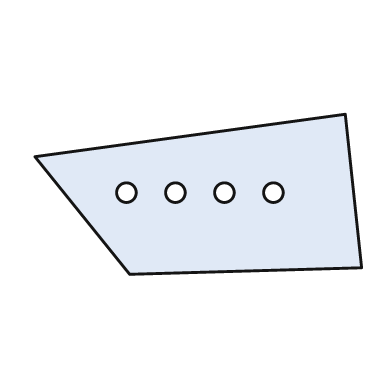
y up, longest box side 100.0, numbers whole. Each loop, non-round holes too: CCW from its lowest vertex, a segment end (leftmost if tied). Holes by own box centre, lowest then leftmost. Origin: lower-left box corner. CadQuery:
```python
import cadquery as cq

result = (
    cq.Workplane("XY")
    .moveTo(29.0, 0.0)
    .lineTo(100.0, 2.0)
    .lineTo(95.0, 49.0)
    .lineTo(0.0, 36.0)
    .close()
    .moveTo(28.0, 25.0)
    .circle(3.0)
    .moveTo(43.0, 25.0)
    .circle(3.0)
    .moveTo(58.0, 25.0)
    .circle(3.0)
    .moveTo(73.0, 25.0)
    .circle(3.0)
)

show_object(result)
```